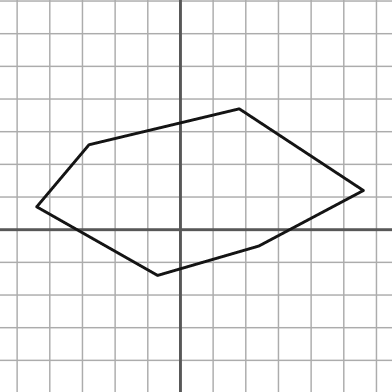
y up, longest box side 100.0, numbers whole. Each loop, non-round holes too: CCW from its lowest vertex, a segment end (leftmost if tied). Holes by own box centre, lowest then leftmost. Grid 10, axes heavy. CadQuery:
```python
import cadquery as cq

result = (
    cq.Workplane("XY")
    .moveTo(-7.0, -14.0)
    .lineTo(24.0, -5.0)
    .lineTo(56.0, 12.0)
    .lineTo(18.0, 37.0)
    .lineTo(-28.0, 26.0)
    .lineTo(-44.0, 7.0)
    .close()
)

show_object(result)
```